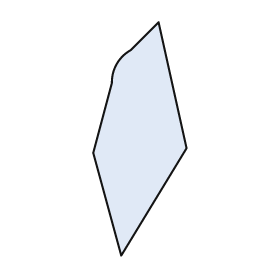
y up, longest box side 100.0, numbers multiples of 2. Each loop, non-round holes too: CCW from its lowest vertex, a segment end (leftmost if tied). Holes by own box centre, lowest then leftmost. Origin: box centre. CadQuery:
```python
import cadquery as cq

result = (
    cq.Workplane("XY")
    .moveTo(-8.0, -50.0)
    .lineTo(20.0, -4.0)
    .lineTo(8.0, 50.0)
    .lineTo(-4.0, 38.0)
    .threePointArc((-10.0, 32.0), (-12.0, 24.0))
    .lineTo(-20.0, -6.0)
    .close()
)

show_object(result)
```